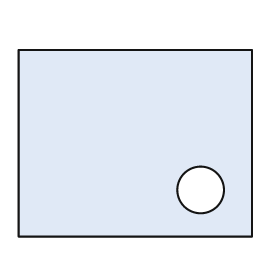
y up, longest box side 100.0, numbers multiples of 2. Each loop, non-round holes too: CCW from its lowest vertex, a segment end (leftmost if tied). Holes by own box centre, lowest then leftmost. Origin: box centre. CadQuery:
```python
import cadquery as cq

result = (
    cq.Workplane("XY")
    .moveTo(-50.0, -40.0)
    .lineTo(50.0, -40.0)
    .lineTo(50.0, 40.0)
    .lineTo(-50.0, 40.0)
    .close()
    .moveTo(28.0, -20.0)
    .circle(10.0)
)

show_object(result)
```